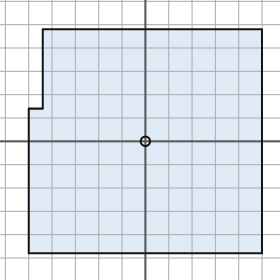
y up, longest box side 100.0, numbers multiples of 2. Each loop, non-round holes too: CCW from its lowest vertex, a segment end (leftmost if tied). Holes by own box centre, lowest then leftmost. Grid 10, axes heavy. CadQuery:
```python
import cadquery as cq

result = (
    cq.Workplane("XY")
    .moveTo(-50.0, -48.0)
    .lineTo(50.0, -48.0)
    .lineTo(50.0, 48.0)
    .lineTo(-44.0, 48.0)
    .lineTo(-44.0, 14.0)
    .lineTo(-50.0, 14.0)
    .close()
    .moveTo(0.0, 0.0)
    .circle(2.0)
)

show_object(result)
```